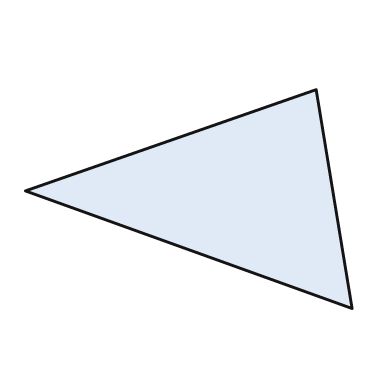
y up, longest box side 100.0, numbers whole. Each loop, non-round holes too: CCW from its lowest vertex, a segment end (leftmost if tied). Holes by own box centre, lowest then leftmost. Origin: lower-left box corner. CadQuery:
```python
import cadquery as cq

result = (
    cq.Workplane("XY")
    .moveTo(100.0, 0.0)
    .lineTo(89.0, 67.0)
    .lineTo(0.0, 36.0)
    .close()
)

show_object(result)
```